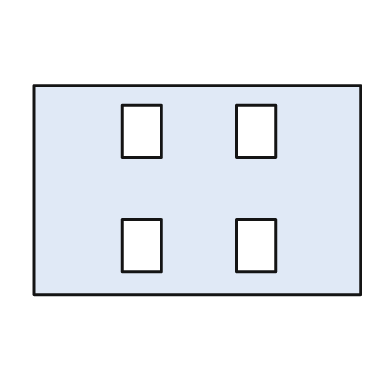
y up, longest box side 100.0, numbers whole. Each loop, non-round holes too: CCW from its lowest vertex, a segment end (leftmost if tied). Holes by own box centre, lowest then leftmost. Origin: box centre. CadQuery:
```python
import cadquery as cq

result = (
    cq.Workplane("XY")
    .moveTo(-50.0, -32.0)
    .lineTo(50.0, -32.0)
    .lineTo(50.0, 32.0)
    .lineTo(-50.0, 32.0)
    .close()
    .moveTo(-23.0, -25.0)
    .lineTo(-11.0, -25.0)
    .lineTo(-11.0, -9.0)
    .lineTo(-23.0, -9.0)
    .close()
    .moveTo(12.0, -25.0)
    .lineTo(24.0, -25.0)
    .lineTo(24.0, -9.0)
    .lineTo(12.0, -9.0)
    .close()
    .moveTo(-23.0, 10.0)
    .lineTo(-11.0, 10.0)
    .lineTo(-11.0, 26.0)
    .lineTo(-23.0, 26.0)
    .close()
    .moveTo(12.0, 10.0)
    .lineTo(24.0, 10.0)
    .lineTo(24.0, 26.0)
    .lineTo(12.0, 26.0)
    .close()
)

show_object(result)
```